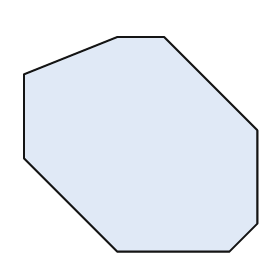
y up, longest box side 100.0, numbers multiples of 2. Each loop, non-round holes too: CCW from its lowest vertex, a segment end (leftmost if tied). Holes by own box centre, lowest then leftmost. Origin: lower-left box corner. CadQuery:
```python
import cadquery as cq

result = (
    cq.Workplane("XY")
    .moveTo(40.0, 0.0)
    .lineTo(88.0, 0.0)
    .lineTo(100.0, 12.0)
    .lineTo(100.0, 52.0)
    .lineTo(60.0, 92.0)
    .lineTo(40.0, 92.0)
    .lineTo(0.0, 76.0)
    .lineTo(0.0, 40.0)
    .close()
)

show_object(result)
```